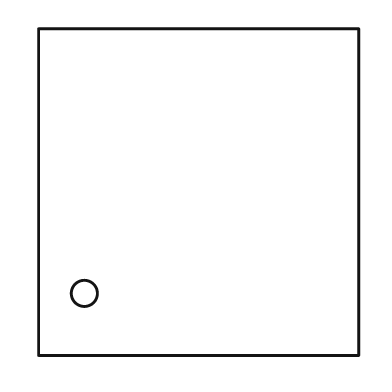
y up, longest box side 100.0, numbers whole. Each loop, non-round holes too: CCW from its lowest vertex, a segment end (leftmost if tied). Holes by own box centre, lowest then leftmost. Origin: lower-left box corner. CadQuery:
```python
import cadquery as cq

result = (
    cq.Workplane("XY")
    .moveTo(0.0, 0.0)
    .lineTo(98.0, 0.0)
    .lineTo(98.0, 100.0)
    .lineTo(0.0, 100.0)
    .close()
    .moveTo(14.0, 19.0)
    .circle(4.0)
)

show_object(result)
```